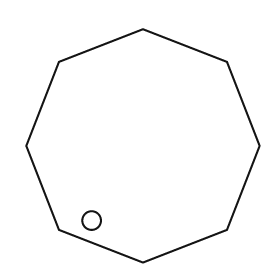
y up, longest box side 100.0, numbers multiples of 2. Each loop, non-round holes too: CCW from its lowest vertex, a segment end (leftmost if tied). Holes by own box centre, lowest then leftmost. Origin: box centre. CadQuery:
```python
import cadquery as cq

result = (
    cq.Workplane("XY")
    .moveTo(0.0, -50.0)
    .lineTo(36.0, -36.0)
    .lineTo(50.0, 0.0)
    .lineTo(36.0, 36.0)
    .lineTo(0.0, 50.0)
    .lineTo(-36.0, 36.0)
    .lineTo(-50.0, 0.0)
    .lineTo(-36.0, -36.0)
    .close()
    .moveTo(-22.0, -32.0)
    .circle(4.0)
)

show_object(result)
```